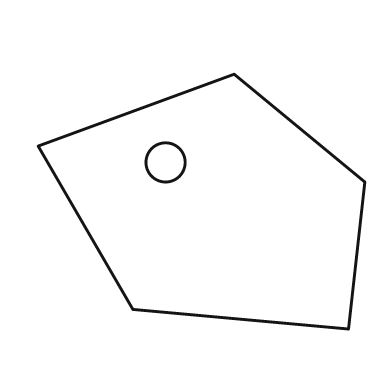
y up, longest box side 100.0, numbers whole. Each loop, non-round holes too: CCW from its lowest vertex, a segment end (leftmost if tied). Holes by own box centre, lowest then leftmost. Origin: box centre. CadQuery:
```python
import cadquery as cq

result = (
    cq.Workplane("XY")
    .moveTo(45.0, -39.0)
    .lineTo(50.0, 6.0)
    .lineTo(10.0, 39.0)
    .lineTo(-50.0, 17.0)
    .lineTo(-21.0, -33.0)
    .close()
    .moveTo(-11.0, 12.0)
    .circle(6.0)
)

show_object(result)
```